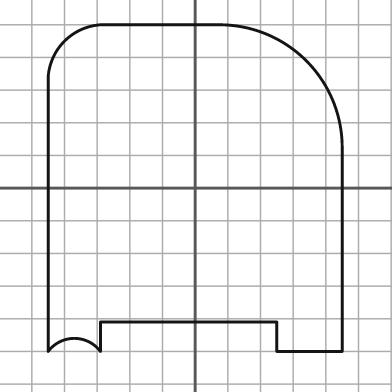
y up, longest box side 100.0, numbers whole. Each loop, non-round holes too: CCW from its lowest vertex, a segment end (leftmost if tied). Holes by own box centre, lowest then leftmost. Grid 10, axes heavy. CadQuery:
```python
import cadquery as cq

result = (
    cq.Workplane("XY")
    .moveTo(-45.0, -50.0)
    .threePointArc((-37.0, -46.0), (-29.0, -50.0))
    .lineTo(-29.0, -41.0)
    .lineTo(25.0, -41.0)
    .lineTo(25.0, -50.0)
    .lineTo(45.0, -50.0)
    .lineTo(45.0, 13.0)
    .threePointArc((34.0, 39.0), (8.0, 50.0))
    .lineTo(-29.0, 50.0)
    .threePointArc((-40.0, 45.0), (-45.0, 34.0))
    .close()
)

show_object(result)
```